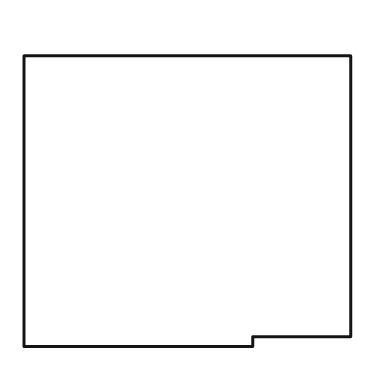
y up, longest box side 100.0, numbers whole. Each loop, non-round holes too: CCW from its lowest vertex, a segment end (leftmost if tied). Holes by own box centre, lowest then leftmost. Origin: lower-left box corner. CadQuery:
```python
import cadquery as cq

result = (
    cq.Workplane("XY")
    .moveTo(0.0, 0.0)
    .lineTo(70.0, 0.0)
    .lineTo(70.0, 3.0)
    .lineTo(100.0, 3.0)
    .lineTo(100.0, 89.0)
    .lineTo(0.0, 89.0)
    .close()
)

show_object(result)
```